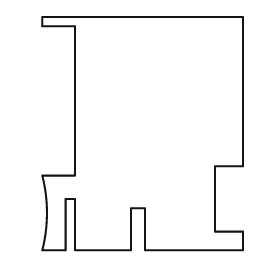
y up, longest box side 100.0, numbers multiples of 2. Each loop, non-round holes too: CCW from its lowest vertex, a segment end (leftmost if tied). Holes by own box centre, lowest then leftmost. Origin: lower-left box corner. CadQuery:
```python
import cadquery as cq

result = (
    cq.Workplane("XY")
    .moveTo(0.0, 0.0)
    .lineTo(10.0, 0.0)
    .lineTo(10.0, 22.0)
    .lineTo(14.0, 22.0)
    .lineTo(14.0, 0.0)
    .lineTo(38.0, 0.0)
    .lineTo(38.0, 18.0)
    .lineTo(44.0, 18.0)
    .lineTo(44.0, 0.0)
    .lineTo(86.0, 0.0)
    .lineTo(86.0, 8.0)
    .lineTo(74.0, 8.0)
    .lineTo(74.0, 36.0)
    .lineTo(86.0, 36.0)
    .lineTo(86.0, 100.0)
    .lineTo(0.0, 100.0)
    .lineTo(0.0, 96.0)
    .lineTo(14.0, 96.0)
    .lineTo(14.0, 32.0)
    .lineTo(0.0, 32.0)
    .threePointArc((2.0, 16.0), (0.0, 0.0))
    .close()
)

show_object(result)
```